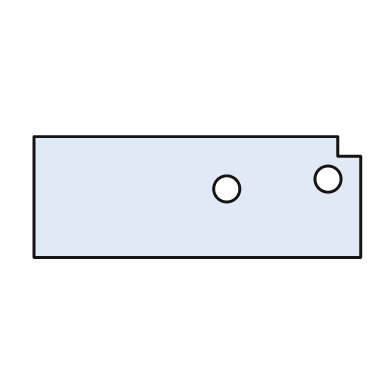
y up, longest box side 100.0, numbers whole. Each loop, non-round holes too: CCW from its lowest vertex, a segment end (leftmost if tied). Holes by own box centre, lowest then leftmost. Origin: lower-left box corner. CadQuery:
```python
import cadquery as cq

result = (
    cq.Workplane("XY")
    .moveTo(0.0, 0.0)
    .lineTo(100.0, 0.0)
    .lineTo(100.0, 31.0)
    .lineTo(93.0, 31.0)
    .lineTo(93.0, 37.0)
    .lineTo(0.0, 37.0)
    .close()
    .moveTo(59.0, 21.0)
    .circle(4.0)
    .moveTo(90.0, 24.0)
    .circle(4.0)
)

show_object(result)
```